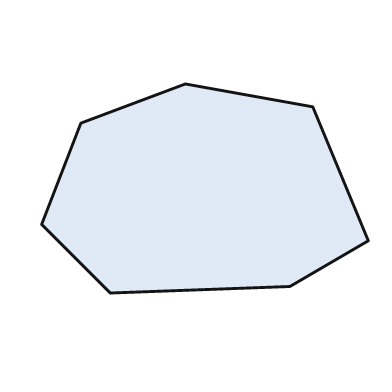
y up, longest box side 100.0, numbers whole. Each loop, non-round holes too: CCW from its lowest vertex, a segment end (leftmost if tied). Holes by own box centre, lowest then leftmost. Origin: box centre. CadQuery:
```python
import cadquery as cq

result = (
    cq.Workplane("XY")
    .moveTo(-29.0, -32.0)
    .lineTo(26.0, -30.0)
    .lineTo(50.0, -16.0)
    .lineTo(33.0, 25.0)
    .lineTo(-6.0, 32.0)
    .lineTo(-38.0, 20.0)
    .lineTo(-50.0, -11.0)
    .close()
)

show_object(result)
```